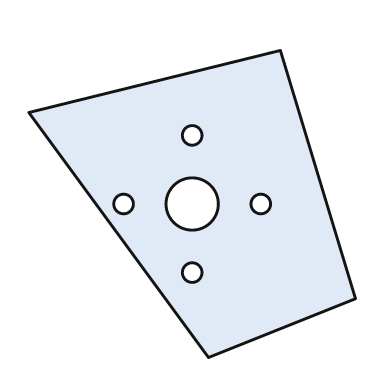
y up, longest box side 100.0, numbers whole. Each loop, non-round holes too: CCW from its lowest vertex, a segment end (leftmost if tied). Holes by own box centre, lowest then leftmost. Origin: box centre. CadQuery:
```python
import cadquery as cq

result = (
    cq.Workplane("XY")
    .moveTo(5.0, -47.0)
    .lineTo(50.0, -29.0)
    .lineTo(27.0, 47.0)
    .lineTo(-50.0, 28.0)
    .close()
    .moveTo(0.0, -21.0)
    .circle(3.0)
    .moveTo(-21.0, 0.0)
    .circle(3.0)
    .moveTo(0.0, 0.0)
    .circle(8.0)
    .moveTo(21.0, 0.0)
    .circle(3.0)
    .moveTo(0.0, 21.0)
    .circle(3.0)
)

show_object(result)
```